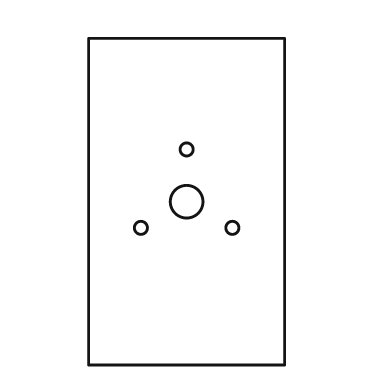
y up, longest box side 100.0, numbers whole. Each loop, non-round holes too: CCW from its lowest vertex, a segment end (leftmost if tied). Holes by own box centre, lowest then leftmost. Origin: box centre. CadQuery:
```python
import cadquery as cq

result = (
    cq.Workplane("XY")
    .moveTo(-30.0, -50.0)
    .lineTo(30.0, -50.0)
    .lineTo(30.0, 50.0)
    .lineTo(-30.0, 50.0)
    .close()
    .moveTo(-14.0, -8.0)
    .circle(2.0)
    .moveTo(14.0, -8.0)
    .circle(2.0)
    .moveTo(0.0, 0.0)
    .circle(5.0)
    .moveTo(0.0, 16.0)
    .circle(2.0)
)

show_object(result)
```